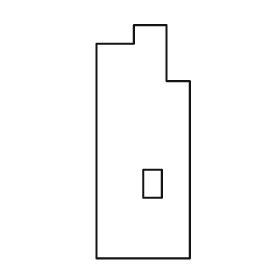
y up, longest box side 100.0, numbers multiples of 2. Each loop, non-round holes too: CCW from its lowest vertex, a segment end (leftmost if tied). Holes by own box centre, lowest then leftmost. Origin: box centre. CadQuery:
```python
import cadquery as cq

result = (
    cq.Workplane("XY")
    .moveTo(-20.0, -50.0)
    .lineTo(20.0, -50.0)
    .lineTo(20.0, 26.0)
    .lineTo(10.0, 26.0)
    .lineTo(10.0, 50.0)
    .lineTo(-4.0, 50.0)
    .lineTo(-4.0, 42.0)
    .lineTo(-20.0, 42.0)
    .close()
    .moveTo(0.0, -24.0)
    .lineTo(8.0, -24.0)
    .lineTo(8.0, -12.0)
    .lineTo(0.0, -12.0)
    .close()
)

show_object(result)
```